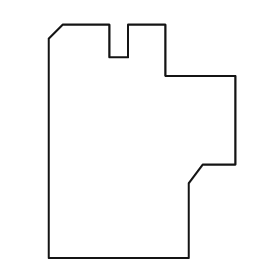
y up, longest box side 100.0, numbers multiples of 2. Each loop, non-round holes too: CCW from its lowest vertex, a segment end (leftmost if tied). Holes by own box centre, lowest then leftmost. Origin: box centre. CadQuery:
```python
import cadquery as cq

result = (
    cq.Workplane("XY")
    .moveTo(-40.0, -50.0)
    .lineTo(20.0, -50.0)
    .lineTo(20.0, -18.0)
    .lineTo(26.0, -10.0)
    .lineTo(40.0, -10.0)
    .lineTo(40.0, 28.0)
    .lineTo(10.0, 28.0)
    .lineTo(10.0, 50.0)
    .lineTo(-6.0, 50.0)
    .lineTo(-6.0, 36.0)
    .lineTo(-14.0, 36.0)
    .lineTo(-14.0, 50.0)
    .lineTo(-34.0, 50.0)
    .lineTo(-40.0, 44.0)
    .close()
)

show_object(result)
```